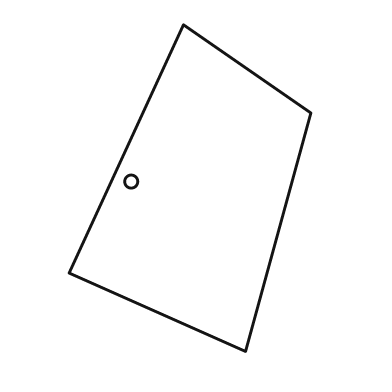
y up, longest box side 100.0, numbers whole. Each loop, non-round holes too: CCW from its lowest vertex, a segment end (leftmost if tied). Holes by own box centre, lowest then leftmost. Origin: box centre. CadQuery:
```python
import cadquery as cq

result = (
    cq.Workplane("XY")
    .moveTo(17.0, -50.0)
    .lineTo(37.0, 23.0)
    .lineTo(-2.0, 50.0)
    .lineTo(-37.0, -26.0)
    .close()
    .moveTo(-18.0, 2.0)
    .circle(2.0)
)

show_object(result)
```